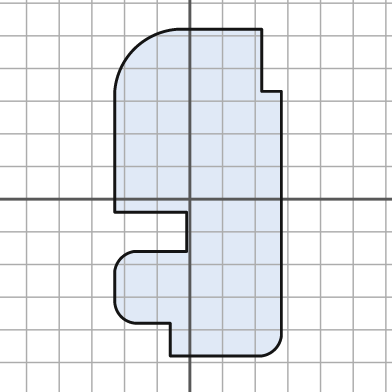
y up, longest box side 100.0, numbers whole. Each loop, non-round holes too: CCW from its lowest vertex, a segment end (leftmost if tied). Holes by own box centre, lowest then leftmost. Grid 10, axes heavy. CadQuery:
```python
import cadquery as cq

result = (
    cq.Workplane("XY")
    .moveTo(-6.0, -48.0)
    .lineTo(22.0, -48.0)
    .threePointArc((26.0, -46.0), (28.0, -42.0))
    .lineTo(28.0, 33.0)
    .lineTo(22.0, 33.0)
    .lineTo(22.0, 52.0)
    .lineTo(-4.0, 52.0)
    .threePointArc((-17.0, 46.0), (-23.0, 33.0))
    .lineTo(-23.0, -4.0)
    .lineTo(-1.0, -4.0)
    .lineTo(-1.0, -16.0)
    .lineTo(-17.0, -16.0)
    .threePointArc((-21.0, -18.0), (-23.0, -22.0))
    .lineTo(-23.0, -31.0)
    .threePointArc((-21.0, -36.0), (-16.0, -38.0))
    .lineTo(-6.0, -38.0)
    .close()
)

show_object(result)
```